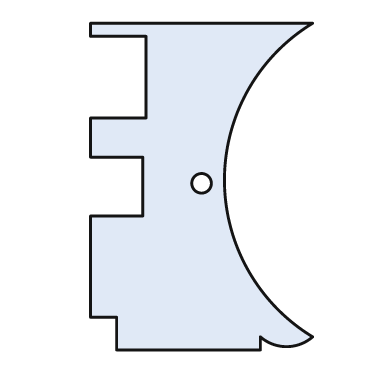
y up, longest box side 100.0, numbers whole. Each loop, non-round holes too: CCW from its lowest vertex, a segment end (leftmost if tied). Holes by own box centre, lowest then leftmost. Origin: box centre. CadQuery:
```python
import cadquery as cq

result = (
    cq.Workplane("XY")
    .moveTo(-26.0, -50.0)
    .lineTo(18.0, -50.0)
    .lineTo(18.0, -46.0)
    .threePointArc((26.0, -49.0), (34.0, -46.0))
    .threePointArc((7.0, 2.0), (34.0, 50.0))
    .lineTo(-34.0, 50.0)
    .lineTo(-34.0, 46.0)
    .lineTo(-17.0, 46.0)
    .lineTo(-17.0, 21.0)
    .lineTo(-34.0, 21.0)
    .lineTo(-34.0, 9.0)
    .lineTo(-18.0, 9.0)
    .lineTo(-18.0, -9.0)
    .lineTo(-34.0, -9.0)
    .lineTo(-34.0, -40.0)
    .lineTo(-26.0, -40.0)
    .close()
    .moveTo(0.0, 1.0)
    .circle(3.0)
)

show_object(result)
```